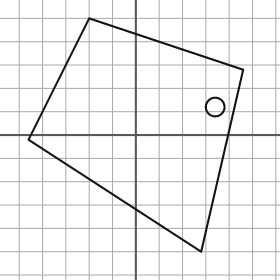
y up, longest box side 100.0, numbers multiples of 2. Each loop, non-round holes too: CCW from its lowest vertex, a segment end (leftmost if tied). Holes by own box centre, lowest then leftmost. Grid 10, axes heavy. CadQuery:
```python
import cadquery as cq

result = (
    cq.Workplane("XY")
    .moveTo(28.0, -50.0)
    .lineTo(46.0, 28.0)
    .lineTo(-20.0, 50.0)
    .lineTo(-46.0, -2.0)
    .close()
    .moveTo(34.0, 12.0)
    .circle(4.0)
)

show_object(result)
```